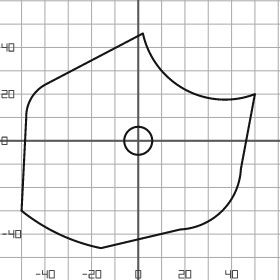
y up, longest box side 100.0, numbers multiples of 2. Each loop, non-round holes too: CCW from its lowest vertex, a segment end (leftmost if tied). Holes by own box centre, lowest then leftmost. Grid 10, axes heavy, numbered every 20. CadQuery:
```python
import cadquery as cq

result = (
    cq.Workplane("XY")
    .moveTo(-16.0, -46.0)
    .lineTo(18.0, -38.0)
    .threePointArc((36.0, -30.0), (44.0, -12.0))
    .lineTo(50.0, 20.0)
    .threePointArc((20.0, 22.0), (2.0, 46.0))
    .lineTo(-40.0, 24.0)
    .threePointArc((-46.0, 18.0), (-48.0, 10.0))
    .lineTo(-50.0, -30.0)
    .threePointArc((-34.0, -40.0), (-16.0, -46.0))
    .close()
    .moveTo(0.0, 0.0)
    .circle(6.0)
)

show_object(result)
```